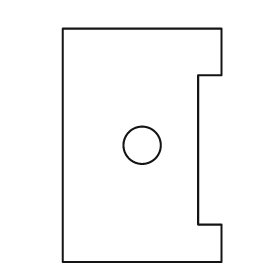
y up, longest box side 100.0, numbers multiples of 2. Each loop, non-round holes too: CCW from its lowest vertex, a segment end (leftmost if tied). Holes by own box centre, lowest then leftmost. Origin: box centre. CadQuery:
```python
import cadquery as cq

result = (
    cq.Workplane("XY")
    .moveTo(-34.0, -50.0)
    .lineTo(34.0, -50.0)
    .lineTo(34.0, -34.0)
    .lineTo(24.0, -34.0)
    .lineTo(24.0, 30.0)
    .lineTo(34.0, 30.0)
    .lineTo(34.0, 50.0)
    .lineTo(-34.0, 50.0)
    .close()
    .moveTo(0.0, 0.0)
    .circle(8.0)
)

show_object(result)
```